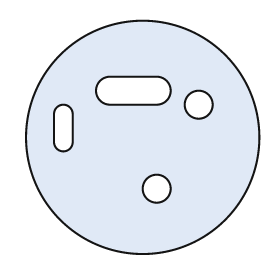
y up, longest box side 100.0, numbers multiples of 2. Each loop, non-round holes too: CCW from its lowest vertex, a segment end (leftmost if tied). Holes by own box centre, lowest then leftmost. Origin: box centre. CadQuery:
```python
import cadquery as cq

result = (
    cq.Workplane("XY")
    .moveTo(0.0, 0.0)
    .circle(50.0)
    .moveTo(6.0, -22.0)
    .circle(6.0)
    .moveTo(-38.0, -2.0)
    .threePointArc((-34.0, -6.0), (-30.0, -2.0))
    .lineTo(-30.0, 10.0)
    .threePointArc((-34.0, 14.0), (-38.0, 10.0))
    .close()
    .moveTo(24.0, 14.0)
    .circle(6.0)
    .moveTo(-14.0, 14.0)
    .lineTo(6.0, 14.0)
    .threePointArc((12.0, 20.0), (6.0, 26.0))
    .lineTo(-14.0, 26.0)
    .threePointArc((-20.0, 20.0), (-14.0, 14.0))
    .close()
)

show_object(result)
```